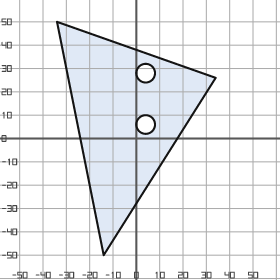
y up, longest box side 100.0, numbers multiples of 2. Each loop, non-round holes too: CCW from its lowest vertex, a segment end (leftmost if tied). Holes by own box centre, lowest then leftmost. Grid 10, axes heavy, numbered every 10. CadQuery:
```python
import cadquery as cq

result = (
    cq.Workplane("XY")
    .moveTo(-14.0, -50.0)
    .lineTo(34.0, 26.0)
    .lineTo(-34.0, 50.0)
    .close()
    .moveTo(4.0, 6.0)
    .circle(4.0)
    .moveTo(4.0, 28.0)
    .circle(4.0)
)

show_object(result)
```